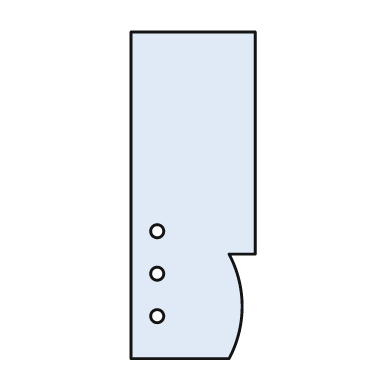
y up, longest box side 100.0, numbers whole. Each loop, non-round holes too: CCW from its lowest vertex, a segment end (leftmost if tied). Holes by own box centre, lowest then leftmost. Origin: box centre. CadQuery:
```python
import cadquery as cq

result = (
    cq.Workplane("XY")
    .moveTo(-19.0, -50.0)
    .lineTo(11.0, -50.0)
    .threePointArc((15.0, -34.0), (11.0, -18.0))
    .lineTo(19.0, -18.0)
    .lineTo(19.0, 50.0)
    .lineTo(-19.0, 50.0)
    .close()
    .moveTo(-11.0, -37.0)
    .circle(2.0)
    .moveTo(-11.0, -24.0)
    .circle(2.0)
    .moveTo(-11.0, -11.0)
    .circle(2.0)
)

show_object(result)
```